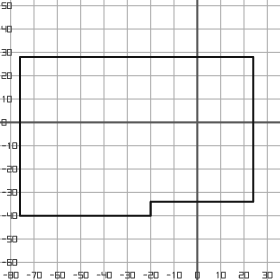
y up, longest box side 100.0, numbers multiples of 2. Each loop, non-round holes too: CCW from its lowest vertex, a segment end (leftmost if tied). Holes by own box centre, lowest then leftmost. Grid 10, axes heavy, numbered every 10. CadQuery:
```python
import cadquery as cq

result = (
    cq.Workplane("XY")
    .moveTo(-76.0, -40.0)
    .lineTo(-20.0, -40.0)
    .lineTo(-20.0, -34.0)
    .lineTo(24.0, -34.0)
    .lineTo(24.0, 28.0)
    .lineTo(-76.0, 28.0)
    .close()
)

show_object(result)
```